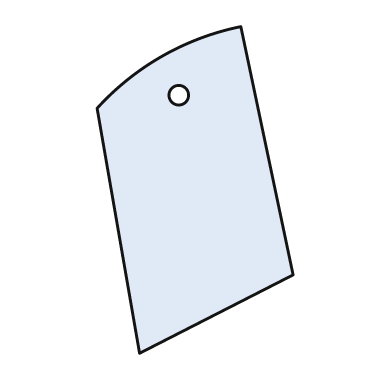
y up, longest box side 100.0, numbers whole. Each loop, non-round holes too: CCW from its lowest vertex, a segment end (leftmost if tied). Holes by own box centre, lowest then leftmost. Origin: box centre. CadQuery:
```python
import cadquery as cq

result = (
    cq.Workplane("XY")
    .moveTo(-17.0, -50.0)
    .lineTo(30.0, -26.0)
    .lineTo(14.0, 50.0)
    .threePointArc((-10.0, 41.0), (-30.0, 25.0))
    .close()
    .moveTo(-5.0, 29.0)
    .circle(3.0)
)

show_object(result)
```